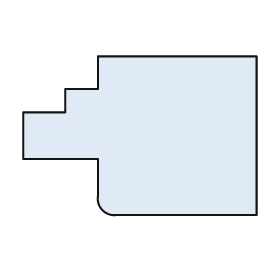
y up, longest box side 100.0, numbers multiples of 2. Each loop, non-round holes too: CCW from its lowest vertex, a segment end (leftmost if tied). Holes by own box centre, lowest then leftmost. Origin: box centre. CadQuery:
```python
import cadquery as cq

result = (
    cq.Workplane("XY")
    .moveTo(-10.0, -34.0)
    .lineTo(50.0, -34.0)
    .lineTo(50.0, 34.0)
    .lineTo(-18.0, 34.0)
    .lineTo(-18.0, 20.0)
    .lineTo(-32.0, 20.0)
    .lineTo(-32.0, 10.0)
    .lineTo(-50.0, 10.0)
    .lineTo(-50.0, -10.0)
    .lineTo(-18.0, -10.0)
    .lineTo(-18.0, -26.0)
    .threePointArc((-16.0, -32.0), (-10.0, -34.0))
    .close()
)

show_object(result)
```